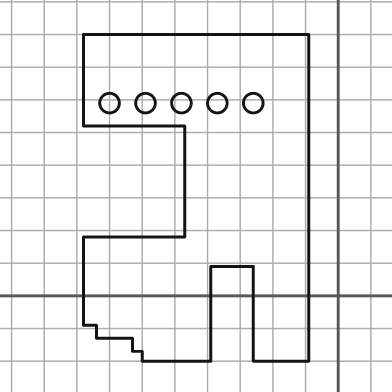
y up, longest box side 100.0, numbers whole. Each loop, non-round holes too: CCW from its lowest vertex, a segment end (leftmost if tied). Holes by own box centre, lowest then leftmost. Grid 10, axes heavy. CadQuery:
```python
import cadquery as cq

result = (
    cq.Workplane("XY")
    .moveTo(-60.0, -20.0)
    .lineTo(-39.0, -20.0)
    .lineTo(-39.0, 9.0)
    .lineTo(-26.0, 9.0)
    .lineTo(-26.0, -20.0)
    .lineTo(-9.0, -20.0)
    .lineTo(-9.0, 80.0)
    .lineTo(-78.0, 80.0)
    .lineTo(-78.0, 52.0)
    .lineTo(-47.0, 52.0)
    .lineTo(-47.0, 18.0)
    .lineTo(-78.0, 18.0)
    .lineTo(-78.0, -9.0)
    .lineTo(-74.0, -9.0)
    .lineTo(-74.0, -13.0)
    .lineTo(-63.0, -13.0)
    .lineTo(-63.0, -17.0)
    .lineTo(-60.0, -17.0)
    .close()
    .moveTo(-70.0, 59.0)
    .circle(3.0)
    .moveTo(-59.0, 59.0)
    .circle(3.0)
    .moveTo(-48.0, 59.0)
    .circle(3.0)
    .moveTo(-37.0, 59.0)
    .circle(3.0)
    .moveTo(-26.0, 59.0)
    .circle(3.0)
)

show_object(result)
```